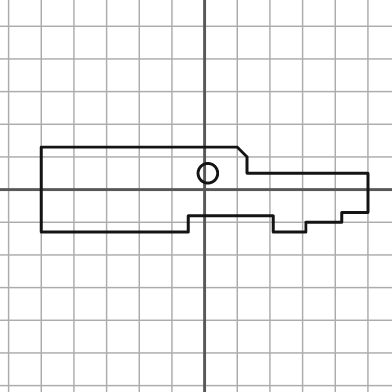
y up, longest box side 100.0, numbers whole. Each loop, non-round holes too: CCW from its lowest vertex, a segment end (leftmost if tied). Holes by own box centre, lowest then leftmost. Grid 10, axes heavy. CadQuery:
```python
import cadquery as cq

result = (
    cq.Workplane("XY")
    .moveTo(-50.0, -13.0)
    .lineTo(-5.0, -13.0)
    .lineTo(-5.0, -8.0)
    .lineTo(21.0, -8.0)
    .lineTo(21.0, -13.0)
    .lineTo(31.0, -13.0)
    .lineTo(31.0, -10.0)
    .lineTo(42.0, -10.0)
    .lineTo(42.0, -7.0)
    .lineTo(50.0, -7.0)
    .lineTo(50.0, 5.0)
    .lineTo(13.0, 5.0)
    .lineTo(13.0, 10.0)
    .lineTo(10.0, 13.0)
    .lineTo(-50.0, 13.0)
    .close()
    .moveTo(1.0, 5.0)
    .circle(3.0)
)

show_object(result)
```